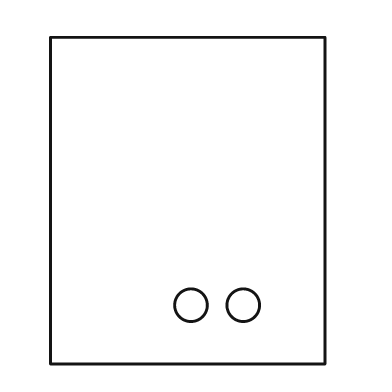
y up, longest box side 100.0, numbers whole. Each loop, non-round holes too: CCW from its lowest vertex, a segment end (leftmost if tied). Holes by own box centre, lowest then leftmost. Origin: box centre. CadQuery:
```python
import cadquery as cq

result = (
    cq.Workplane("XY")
    .moveTo(-42.0, -50.0)
    .lineTo(42.0, -50.0)
    .lineTo(42.0, 50.0)
    .lineTo(-42.0, 50.0)
    .close()
    .moveTo(1.0, -32.0)
    .circle(5.0)
    .moveTo(17.0, -32.0)
    .circle(5.0)
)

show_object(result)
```